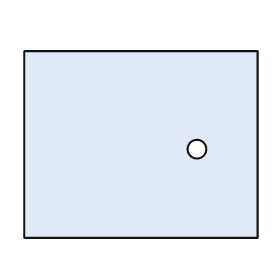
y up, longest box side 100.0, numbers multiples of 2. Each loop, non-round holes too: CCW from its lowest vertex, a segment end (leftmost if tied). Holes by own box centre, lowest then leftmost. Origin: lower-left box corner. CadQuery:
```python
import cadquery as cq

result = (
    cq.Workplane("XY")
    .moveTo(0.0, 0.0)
    .lineTo(100.0, 0.0)
    .lineTo(100.0, 80.0)
    .lineTo(0.0, 80.0)
    .close()
    .moveTo(74.0, 38.0)
    .circle(4.0)
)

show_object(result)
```